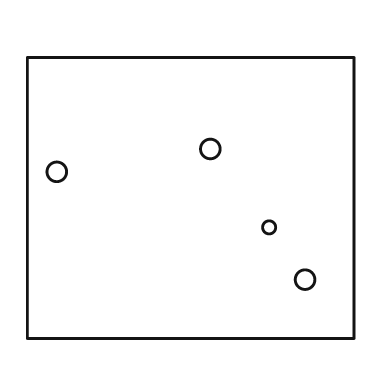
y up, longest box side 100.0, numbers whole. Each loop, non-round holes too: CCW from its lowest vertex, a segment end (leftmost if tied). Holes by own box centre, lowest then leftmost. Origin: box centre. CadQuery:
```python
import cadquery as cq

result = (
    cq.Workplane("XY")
    .moveTo(-50.0, -43.0)
    .lineTo(50.0, -43.0)
    .lineTo(50.0, 43.0)
    .lineTo(-50.0, 43.0)
    .close()
    .moveTo(35.0, -25.0)
    .circle(3.0)
    .moveTo(24.0, -9.0)
    .circle(2.0)
    .moveTo(-41.0, 8.0)
    .circle(3.0)
    .moveTo(6.0, 15.0)
    .circle(3.0)
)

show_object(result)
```